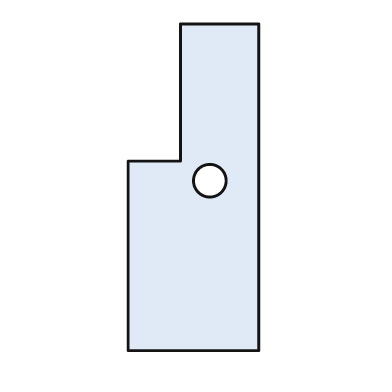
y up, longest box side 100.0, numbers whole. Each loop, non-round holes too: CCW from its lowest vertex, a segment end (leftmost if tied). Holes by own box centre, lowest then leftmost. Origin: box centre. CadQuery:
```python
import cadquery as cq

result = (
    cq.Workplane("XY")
    .moveTo(-20.0, -50.0)
    .lineTo(20.0, -50.0)
    .lineTo(20.0, 50.0)
    .lineTo(-4.0, 50.0)
    .lineTo(-4.0, 8.0)
    .lineTo(-20.0, 8.0)
    .close()
    .moveTo(5.0, 2.0)
    .circle(5.0)
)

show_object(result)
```